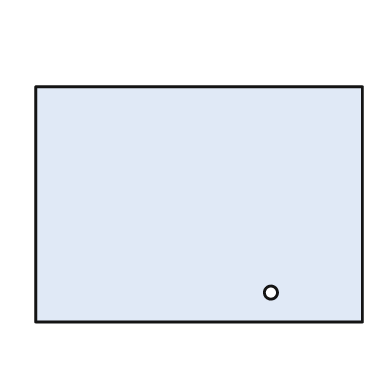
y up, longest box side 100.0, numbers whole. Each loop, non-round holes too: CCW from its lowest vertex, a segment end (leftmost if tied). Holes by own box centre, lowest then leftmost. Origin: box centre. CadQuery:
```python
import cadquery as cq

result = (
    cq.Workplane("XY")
    .moveTo(-50.0, -36.0)
    .lineTo(50.0, -36.0)
    .lineTo(50.0, 36.0)
    .lineTo(-50.0, 36.0)
    .close()
    .moveTo(22.0, -27.0)
    .circle(2.0)
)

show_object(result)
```